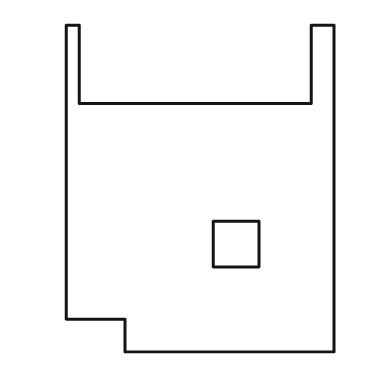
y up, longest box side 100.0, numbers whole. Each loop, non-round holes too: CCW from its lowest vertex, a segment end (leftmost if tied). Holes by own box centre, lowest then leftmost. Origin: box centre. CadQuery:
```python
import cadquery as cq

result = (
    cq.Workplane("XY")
    .moveTo(-23.0, -50.0)
    .lineTo(41.0, -50.0)
    .lineTo(41.0, 50.0)
    .lineTo(34.0, 50.0)
    .lineTo(34.0, 26.0)
    .lineTo(-37.0, 26.0)
    .lineTo(-37.0, 50.0)
    .lineTo(-41.0, 50.0)
    .lineTo(-41.0, -40.0)
    .lineTo(-23.0, -40.0)
    .close()
    .moveTo(4.0, -24.0)
    .lineTo(18.0, -24.0)
    .lineTo(18.0, -10.0)
    .lineTo(4.0, -10.0)
    .close()
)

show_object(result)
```